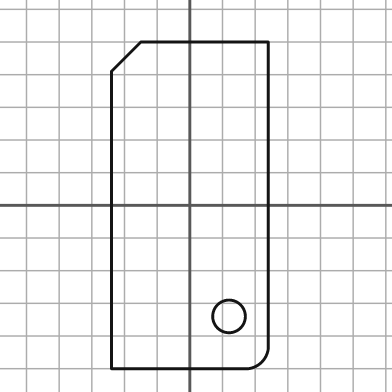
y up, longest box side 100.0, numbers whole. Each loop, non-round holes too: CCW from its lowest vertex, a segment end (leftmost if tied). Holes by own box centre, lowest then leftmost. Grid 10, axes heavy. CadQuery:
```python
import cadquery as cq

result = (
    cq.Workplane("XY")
    .moveTo(-24.0, -50.0)
    .lineTo(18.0, -50.0)
    .threePointArc((22.0, -48.0), (24.0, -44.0))
    .lineTo(24.0, 50.0)
    .lineTo(-15.0, 50.0)
    .lineTo(-24.0, 41.0)
    .close()
    .moveTo(12.0, -34.0)
    .circle(5.0)
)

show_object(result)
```